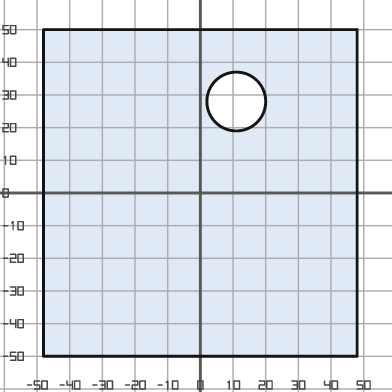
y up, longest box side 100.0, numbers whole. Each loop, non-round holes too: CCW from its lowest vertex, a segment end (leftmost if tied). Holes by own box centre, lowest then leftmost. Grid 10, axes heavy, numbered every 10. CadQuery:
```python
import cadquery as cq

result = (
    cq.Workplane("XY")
    .moveTo(-48.0, -50.0)
    .lineTo(48.0, -50.0)
    .lineTo(48.0, 50.0)
    .lineTo(-48.0, 50.0)
    .close()
    .moveTo(11.0, 28.0)
    .circle(9.0)
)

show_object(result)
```